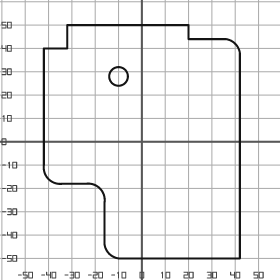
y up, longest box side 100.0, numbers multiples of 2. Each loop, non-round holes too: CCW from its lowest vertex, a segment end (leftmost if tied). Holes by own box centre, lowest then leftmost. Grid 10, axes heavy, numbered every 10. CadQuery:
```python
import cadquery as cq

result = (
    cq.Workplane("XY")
    .moveTo(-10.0, -50.0)
    .lineTo(42.0, -50.0)
    .lineTo(42.0, 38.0)
    .threePointArc((40.0, 42.0), (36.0, 44.0))
    .lineTo(20.0, 44.0)
    .lineTo(20.0, 50.0)
    .lineTo(-32.0, 50.0)
    .lineTo(-32.0, 40.0)
    .lineTo(-42.0, 40.0)
    .lineTo(-42.0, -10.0)
    .threePointArc((-40.0, -16.0), (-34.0, -18.0))
    .lineTo(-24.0, -18.0)
    .threePointArc((-18.0, -20.0), (-16.0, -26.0))
    .lineTo(-16.0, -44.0)
    .threePointArc((-14.0, -48.0), (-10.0, -50.0))
    .close()
    .moveTo(-10.0, 28.0)
    .circle(4.0)
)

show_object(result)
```